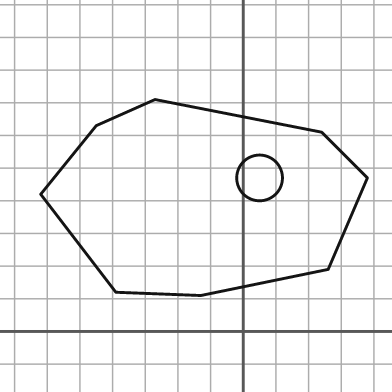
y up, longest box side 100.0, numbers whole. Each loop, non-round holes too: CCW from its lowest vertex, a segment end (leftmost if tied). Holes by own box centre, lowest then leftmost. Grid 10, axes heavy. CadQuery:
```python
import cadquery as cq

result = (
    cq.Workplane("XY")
    .moveTo(-13.0, 11.0)
    .lineTo(26.0, 19.0)
    .lineTo(38.0, 47.0)
    .lineTo(24.0, 61.0)
    .lineTo(-27.0, 71.0)
    .lineTo(-45.0, 63.0)
    .lineTo(-62.0, 42.0)
    .lineTo(-39.0, 12.0)
    .close()
    .moveTo(5.0, 47.0)
    .circle(7.0)
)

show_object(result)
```